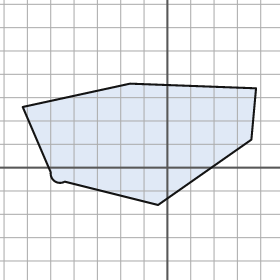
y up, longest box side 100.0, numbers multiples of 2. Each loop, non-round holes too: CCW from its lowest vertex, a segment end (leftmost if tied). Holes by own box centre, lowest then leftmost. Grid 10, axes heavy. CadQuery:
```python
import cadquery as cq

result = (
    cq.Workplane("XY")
    .moveTo(-4.0, -16.0)
    .lineTo(36.0, 12.0)
    .lineTo(38.0, 34.0)
    .lineTo(-16.0, 36.0)
    .lineTo(-62.0, 26.0)
    .lineTo(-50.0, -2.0)
    .threePointArc((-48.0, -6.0), (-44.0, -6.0))
    .close()
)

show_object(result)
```